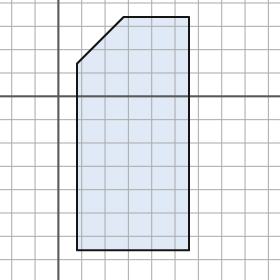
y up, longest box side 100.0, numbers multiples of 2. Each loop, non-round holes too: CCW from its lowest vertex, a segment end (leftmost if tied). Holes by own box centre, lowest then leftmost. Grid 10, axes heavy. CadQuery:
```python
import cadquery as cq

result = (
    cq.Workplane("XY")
    .moveTo(8.0, -66.0)
    .lineTo(56.0, -66.0)
    .lineTo(56.0, 34.0)
    .lineTo(28.0, 34.0)
    .lineTo(8.0, 14.0)
    .close()
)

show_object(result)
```